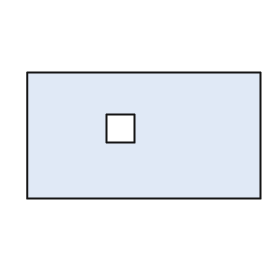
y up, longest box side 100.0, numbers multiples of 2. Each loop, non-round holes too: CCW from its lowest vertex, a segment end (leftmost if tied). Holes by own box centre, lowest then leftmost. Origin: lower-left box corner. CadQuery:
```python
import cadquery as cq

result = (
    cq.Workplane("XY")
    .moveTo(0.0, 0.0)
    .lineTo(100.0, 0.0)
    .lineTo(100.0, 54.0)
    .lineTo(0.0, 54.0)
    .close()
    .moveTo(34.0, 24.0)
    .lineTo(46.0, 24.0)
    .lineTo(46.0, 36.0)
    .lineTo(34.0, 36.0)
    .close()
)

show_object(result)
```